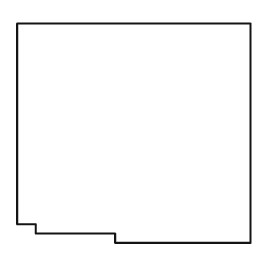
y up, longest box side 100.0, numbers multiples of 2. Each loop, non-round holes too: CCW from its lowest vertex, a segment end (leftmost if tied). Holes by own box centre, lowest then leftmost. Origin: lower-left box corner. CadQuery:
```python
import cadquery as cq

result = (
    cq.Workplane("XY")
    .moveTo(42.0, 0.0)
    .lineTo(100.0, 0.0)
    .lineTo(100.0, 94.0)
    .lineTo(0.0, 94.0)
    .lineTo(0.0, 8.0)
    .lineTo(8.0, 8.0)
    .lineTo(8.0, 4.0)
    .lineTo(42.0, 4.0)
    .close()
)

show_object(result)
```